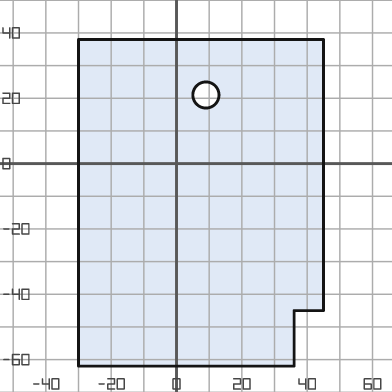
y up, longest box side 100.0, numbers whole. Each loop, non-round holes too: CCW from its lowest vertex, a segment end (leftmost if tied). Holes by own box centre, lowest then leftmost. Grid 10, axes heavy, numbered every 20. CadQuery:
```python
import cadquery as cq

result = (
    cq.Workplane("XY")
    .moveTo(-30.0, -62.0)
    .lineTo(36.0, -62.0)
    .lineTo(36.0, -45.0)
    .lineTo(45.0, -45.0)
    .lineTo(45.0, 38.0)
    .lineTo(-30.0, 38.0)
    .close()
    .moveTo(9.0, 21.0)
    .circle(4.0)
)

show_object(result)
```